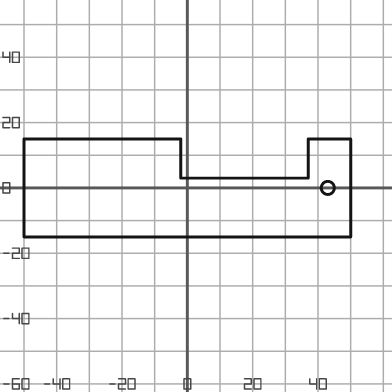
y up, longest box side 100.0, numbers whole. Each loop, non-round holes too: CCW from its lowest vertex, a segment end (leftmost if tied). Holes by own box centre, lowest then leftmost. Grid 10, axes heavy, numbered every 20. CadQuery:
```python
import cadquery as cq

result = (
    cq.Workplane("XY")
    .moveTo(-50.0, -15.0)
    .lineTo(50.0, -15.0)
    .lineTo(50.0, 15.0)
    .lineTo(37.0, 15.0)
    .lineTo(37.0, 3.0)
    .lineTo(-2.0, 3.0)
    .lineTo(-2.0, 15.0)
    .lineTo(-50.0, 15.0)
    .close()
    .moveTo(43.0, 0.0)
    .circle(2.0)
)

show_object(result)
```